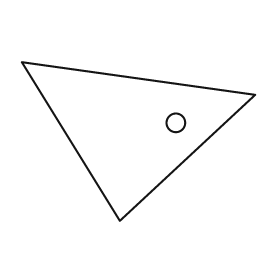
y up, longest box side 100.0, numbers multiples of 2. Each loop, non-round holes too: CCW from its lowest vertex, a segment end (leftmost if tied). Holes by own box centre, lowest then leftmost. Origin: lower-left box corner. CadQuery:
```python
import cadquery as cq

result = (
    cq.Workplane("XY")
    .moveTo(42.0, 0.0)
    .lineTo(100.0, 54.0)
    .lineTo(0.0, 68.0)
    .close()
    .moveTo(66.0, 42.0)
    .circle(4.0)
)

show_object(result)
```